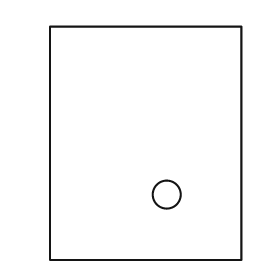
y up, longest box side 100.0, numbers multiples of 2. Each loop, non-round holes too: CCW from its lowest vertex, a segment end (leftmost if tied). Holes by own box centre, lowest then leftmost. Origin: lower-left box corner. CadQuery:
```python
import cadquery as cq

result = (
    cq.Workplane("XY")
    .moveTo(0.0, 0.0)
    .lineTo(82.0, 0.0)
    .lineTo(82.0, 100.0)
    .lineTo(0.0, 100.0)
    .close()
    .moveTo(50.0, 28.0)
    .circle(6.0)
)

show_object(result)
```